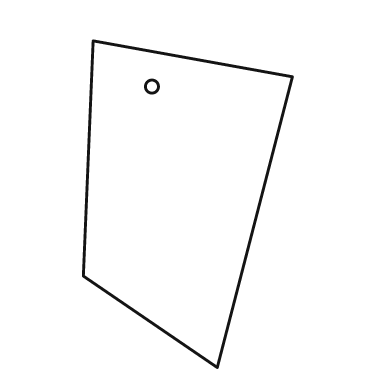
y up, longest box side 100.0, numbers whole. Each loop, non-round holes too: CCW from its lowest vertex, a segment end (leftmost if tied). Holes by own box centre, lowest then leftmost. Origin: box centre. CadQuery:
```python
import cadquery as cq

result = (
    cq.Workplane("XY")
    .moveTo(9.0, -50.0)
    .lineTo(32.0, 39.0)
    .lineTo(-29.0, 50.0)
    .lineTo(-32.0, -22.0)
    .close()
    .moveTo(-11.0, 36.0)
    .circle(2.0)
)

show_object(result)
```